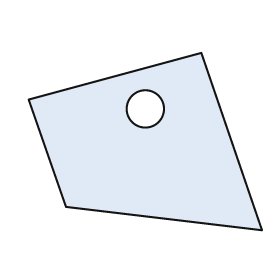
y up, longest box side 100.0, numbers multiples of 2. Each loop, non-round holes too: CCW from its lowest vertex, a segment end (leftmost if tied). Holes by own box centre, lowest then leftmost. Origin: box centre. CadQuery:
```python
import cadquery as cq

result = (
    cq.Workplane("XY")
    .moveTo(50.0, -38.0)
    .lineTo(24.0, 38.0)
    .lineTo(-50.0, 18.0)
    .lineTo(-34.0, -28.0)
    .close()
    .moveTo(0.0, 14.0)
    .circle(8.0)
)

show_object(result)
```